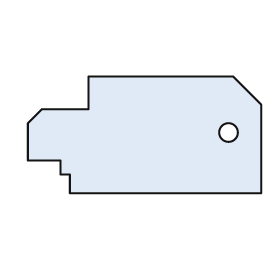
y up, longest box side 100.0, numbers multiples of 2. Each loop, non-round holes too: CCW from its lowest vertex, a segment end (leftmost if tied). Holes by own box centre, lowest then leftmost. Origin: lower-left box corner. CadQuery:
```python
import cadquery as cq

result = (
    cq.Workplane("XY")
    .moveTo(18.0, 0.0)
    .lineTo(100.0, 0.0)
    .lineTo(100.0, 38.0)
    .lineTo(88.0, 50.0)
    .lineTo(26.0, 50.0)
    .lineTo(26.0, 36.0)
    .lineTo(6.0, 36.0)
    .lineTo(0.0, 30.0)
    .lineTo(0.0, 14.0)
    .lineTo(14.0, 14.0)
    .lineTo(14.0, 8.0)
    .lineTo(18.0, 8.0)
    .close()
    .moveTo(86.0, 26.0)
    .circle(4.0)
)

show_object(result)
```